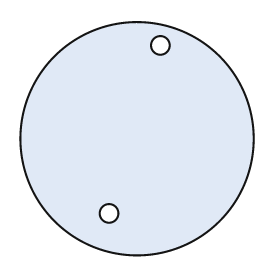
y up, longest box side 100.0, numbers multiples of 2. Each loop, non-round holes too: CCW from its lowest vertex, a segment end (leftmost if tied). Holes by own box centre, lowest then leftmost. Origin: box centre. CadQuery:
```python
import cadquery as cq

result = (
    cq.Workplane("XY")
    .moveTo(0.0, 0.0)
    .circle(50.0)
    .moveTo(-12.0, -32.0)
    .circle(4.0)
    .moveTo(10.0, 40.0)
    .circle(4.0)
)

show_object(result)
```